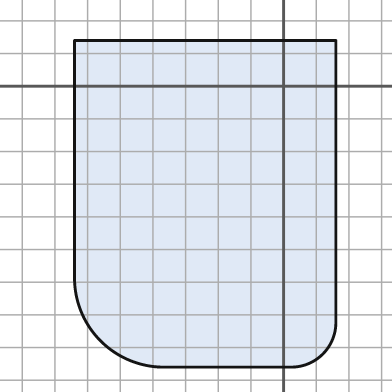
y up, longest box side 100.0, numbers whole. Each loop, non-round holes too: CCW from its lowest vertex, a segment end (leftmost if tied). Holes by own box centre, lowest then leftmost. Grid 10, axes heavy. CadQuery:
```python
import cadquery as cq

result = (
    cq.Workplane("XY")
    .moveTo(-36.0, -86.0)
    .lineTo(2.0, -86.0)
    .threePointArc((12.0, -82.0), (16.0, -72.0))
    .lineTo(16.0, 14.0)
    .lineTo(-64.0, 14.0)
    .lineTo(-64.0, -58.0)
    .threePointArc((-56.0, -78.0), (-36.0, -86.0))
    .close()
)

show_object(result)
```